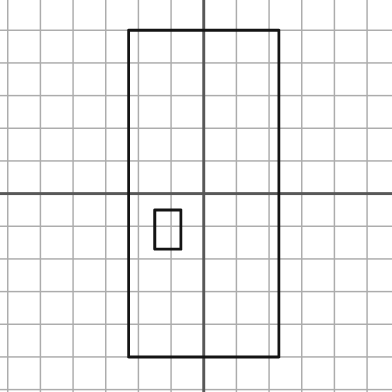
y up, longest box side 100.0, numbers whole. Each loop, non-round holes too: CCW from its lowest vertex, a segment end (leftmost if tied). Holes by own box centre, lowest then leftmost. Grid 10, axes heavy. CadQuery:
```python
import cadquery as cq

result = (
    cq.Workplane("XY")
    .moveTo(-23.0, -50.0)
    .lineTo(23.0, -50.0)
    .lineTo(23.0, 50.0)
    .lineTo(-23.0, 50.0)
    .close()
    .moveTo(-15.0, -17.0)
    .lineTo(-7.0, -17.0)
    .lineTo(-7.0, -5.0)
    .lineTo(-15.0, -5.0)
    .close()
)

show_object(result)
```